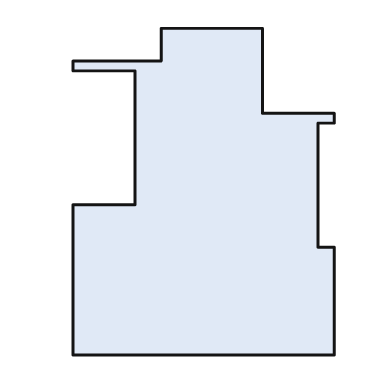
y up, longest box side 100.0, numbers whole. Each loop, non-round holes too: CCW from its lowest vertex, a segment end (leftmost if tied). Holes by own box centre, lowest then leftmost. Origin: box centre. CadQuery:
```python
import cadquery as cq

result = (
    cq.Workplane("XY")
    .moveTo(-40.0, -50.0)
    .lineTo(40.0, -50.0)
    .lineTo(40.0, -17.0)
    .lineTo(35.0, -17.0)
    .lineTo(35.0, 21.0)
    .lineTo(40.0, 21.0)
    .lineTo(40.0, 24.0)
    .lineTo(18.0, 24.0)
    .lineTo(18.0, 50.0)
    .lineTo(-13.0, 50.0)
    .lineTo(-13.0, 40.0)
    .lineTo(-40.0, 40.0)
    .lineTo(-40.0, 37.0)
    .lineTo(-21.0, 37.0)
    .lineTo(-21.0, -4.0)
    .lineTo(-40.0, -4.0)
    .close()
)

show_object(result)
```